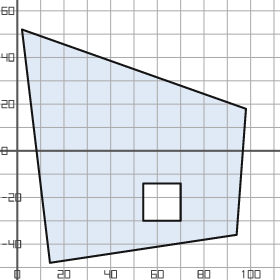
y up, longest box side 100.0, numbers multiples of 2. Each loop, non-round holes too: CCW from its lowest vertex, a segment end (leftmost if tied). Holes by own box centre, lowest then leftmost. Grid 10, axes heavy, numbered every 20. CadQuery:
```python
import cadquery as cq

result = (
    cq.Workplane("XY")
    .moveTo(14.0, -48.0)
    .lineTo(94.0, -36.0)
    .lineTo(98.0, 18.0)
    .lineTo(2.0, 52.0)
    .close()
    .moveTo(54.0, -30.0)
    .lineTo(70.0, -30.0)
    .lineTo(70.0, -14.0)
    .lineTo(54.0, -14.0)
    .close()
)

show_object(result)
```